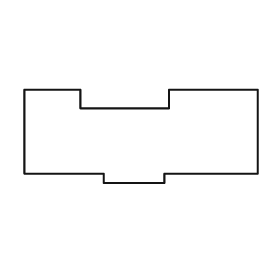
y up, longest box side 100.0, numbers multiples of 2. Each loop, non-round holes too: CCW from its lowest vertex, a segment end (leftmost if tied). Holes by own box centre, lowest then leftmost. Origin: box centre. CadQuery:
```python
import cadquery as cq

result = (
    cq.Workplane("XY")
    .moveTo(-16.0, -20.0)
    .lineTo(10.0, -20.0)
    .lineTo(10.0, -16.0)
    .lineTo(50.0, -16.0)
    .lineTo(50.0, 20.0)
    .lineTo(12.0, 20.0)
    .lineTo(12.0, 12.0)
    .lineTo(-26.0, 12.0)
    .lineTo(-26.0, 20.0)
    .lineTo(-50.0, 20.0)
    .lineTo(-50.0, -16.0)
    .lineTo(-16.0, -16.0)
    .close()
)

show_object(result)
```